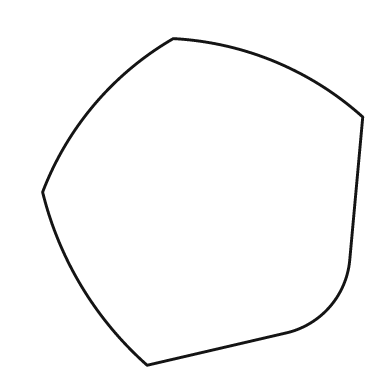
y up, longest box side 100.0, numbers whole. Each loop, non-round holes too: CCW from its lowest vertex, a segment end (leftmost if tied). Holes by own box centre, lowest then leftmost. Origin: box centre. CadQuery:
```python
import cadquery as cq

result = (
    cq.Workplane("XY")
    .moveTo(-17.0, -50.0)
    .lineTo(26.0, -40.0)
    .threePointArc((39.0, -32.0), (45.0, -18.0))
    .lineTo(49.0, 26.0)
    .threePointArc((22.0, 43.0), (-9.0, 50.0))
    .threePointArc((-33.0, 30.0), (-49.0, 3.0))
    .threePointArc((-37.0, -26.0), (-17.0, -50.0))
    .close()
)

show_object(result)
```